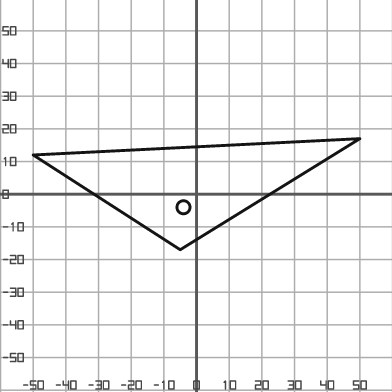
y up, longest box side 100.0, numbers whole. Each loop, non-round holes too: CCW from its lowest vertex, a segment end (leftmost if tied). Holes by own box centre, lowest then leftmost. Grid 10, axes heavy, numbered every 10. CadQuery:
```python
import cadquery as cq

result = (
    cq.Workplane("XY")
    .moveTo(-5.0, -17.0)
    .lineTo(50.0, 17.0)
    .lineTo(-50.0, 12.0)
    .close()
    .moveTo(-4.0, -4.0)
    .circle(2.0)
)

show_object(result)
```